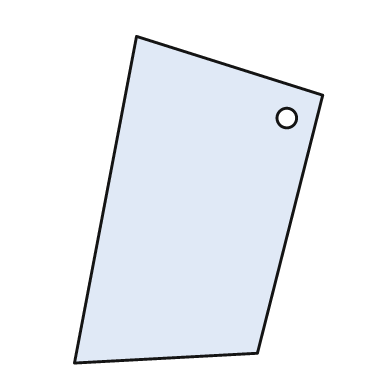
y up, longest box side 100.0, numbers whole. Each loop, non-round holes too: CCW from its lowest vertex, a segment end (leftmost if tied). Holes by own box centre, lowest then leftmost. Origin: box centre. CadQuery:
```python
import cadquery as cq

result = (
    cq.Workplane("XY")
    .moveTo(-38.0, -50.0)
    .lineTo(18.0, -47.0)
    .lineTo(38.0, 32.0)
    .lineTo(-19.0, 50.0)
    .close()
    .moveTo(27.0, 25.0)
    .circle(3.0)
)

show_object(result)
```